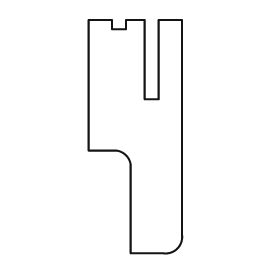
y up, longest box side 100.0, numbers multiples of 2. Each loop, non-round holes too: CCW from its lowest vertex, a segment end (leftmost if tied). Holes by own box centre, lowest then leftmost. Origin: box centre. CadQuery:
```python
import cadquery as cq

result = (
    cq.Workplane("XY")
    .moveTo(-2.0, -50.0)
    .lineTo(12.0, -50.0)
    .threePointArc((18.0, -48.0), (20.0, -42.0))
    .lineTo(20.0, 50.0)
    .lineTo(10.0, 50.0)
    .lineTo(10.0, 16.0)
    .lineTo(4.0, 16.0)
    .lineTo(4.0, 50.0)
    .lineTo(-4.0, 50.0)
    .lineTo(-4.0, 46.0)
    .lineTo(-10.0, 46.0)
    .lineTo(-10.0, 50.0)
    .lineTo(-20.0, 50.0)
    .lineTo(-20.0, -6.0)
    .lineTo(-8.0, -6.0)
    .threePointArc((-4.0, -8.0), (-2.0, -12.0))
    .close()
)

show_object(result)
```